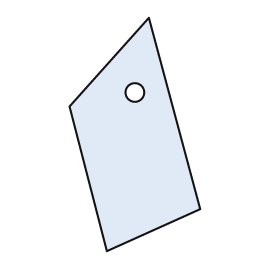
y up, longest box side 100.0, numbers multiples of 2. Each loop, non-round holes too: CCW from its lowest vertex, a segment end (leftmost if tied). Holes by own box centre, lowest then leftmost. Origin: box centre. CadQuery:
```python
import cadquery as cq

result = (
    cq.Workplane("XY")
    .moveTo(-12.0, -50.0)
    .lineTo(28.0, -32.0)
    .lineTo(6.0, 50.0)
    .lineTo(-28.0, 12.0)
    .close()
    .moveTo(0.0, 18.0)
    .circle(4.0)
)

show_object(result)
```